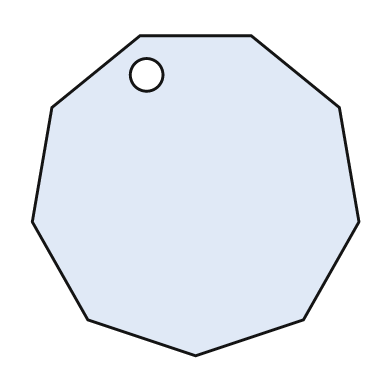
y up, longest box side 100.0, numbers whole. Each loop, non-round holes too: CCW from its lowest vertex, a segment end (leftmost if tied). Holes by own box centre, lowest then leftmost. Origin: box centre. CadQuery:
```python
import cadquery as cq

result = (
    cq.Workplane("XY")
    .moveTo(0.0, -49.0)
    .lineTo(33.0, -38.0)
    .lineTo(50.0, -8.0)
    .lineTo(44.0, 27.0)
    .lineTo(17.0, 49.0)
    .lineTo(-17.0, 49.0)
    .lineTo(-44.0, 27.0)
    .lineTo(-50.0, -8.0)
    .lineTo(-33.0, -38.0)
    .close()
    .moveTo(-15.0, 37.0)
    .circle(5.0)
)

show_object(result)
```